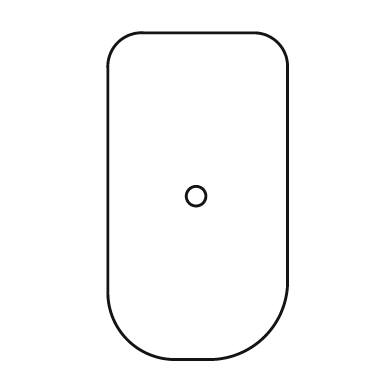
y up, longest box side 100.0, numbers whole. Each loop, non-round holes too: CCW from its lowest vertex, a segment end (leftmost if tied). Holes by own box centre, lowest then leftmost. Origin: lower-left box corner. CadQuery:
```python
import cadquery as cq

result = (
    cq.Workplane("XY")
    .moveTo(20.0, 0.0)
    .lineTo(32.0, 0.0)
    .threePointArc((48.0, 7.0), (55.0, 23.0))
    .lineTo(55.0, 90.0)
    .threePointArc((52.0, 97.0), (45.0, 100.0))
    .lineTo(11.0, 100.0)
    .threePointArc((3.0, 97.0), (0.0, 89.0))
    .lineTo(0.0, 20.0)
    .threePointArc((6.0, 6.0), (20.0, 0.0))
    .close()
    .moveTo(27.0, 50.0)
    .circle(3.0)
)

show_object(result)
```